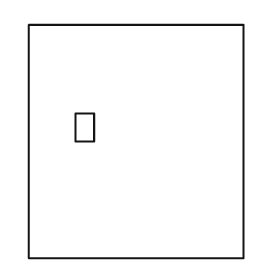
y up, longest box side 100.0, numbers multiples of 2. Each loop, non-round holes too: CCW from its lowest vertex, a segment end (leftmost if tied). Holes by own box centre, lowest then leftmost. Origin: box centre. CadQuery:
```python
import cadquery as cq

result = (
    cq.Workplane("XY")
    .moveTo(-46.0, -50.0)
    .lineTo(46.0, -50.0)
    .lineTo(46.0, 50.0)
    .lineTo(-46.0, 50.0)
    .close()
    .moveTo(-26.0, 0.0)
    .lineTo(-18.0, 0.0)
    .lineTo(-18.0, 12.0)
    .lineTo(-26.0, 12.0)
    .close()
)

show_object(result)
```